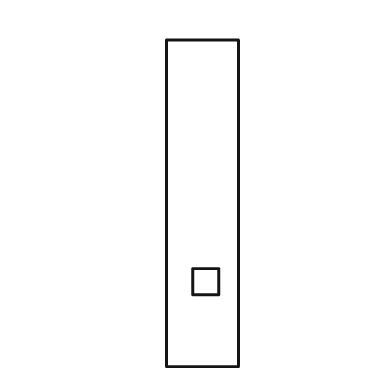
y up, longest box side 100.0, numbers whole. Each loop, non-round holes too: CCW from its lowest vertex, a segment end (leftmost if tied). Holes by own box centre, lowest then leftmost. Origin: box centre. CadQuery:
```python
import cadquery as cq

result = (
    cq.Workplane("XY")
    .moveTo(-11.0, -50.0)
    .lineTo(11.0, -50.0)
    .lineTo(11.0, 50.0)
    .lineTo(-11.0, 50.0)
    .close()
    .moveTo(-3.0, -28.0)
    .lineTo(5.0, -28.0)
    .lineTo(5.0, -20.0)
    .lineTo(-3.0, -20.0)
    .close()
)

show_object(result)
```